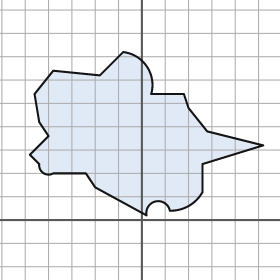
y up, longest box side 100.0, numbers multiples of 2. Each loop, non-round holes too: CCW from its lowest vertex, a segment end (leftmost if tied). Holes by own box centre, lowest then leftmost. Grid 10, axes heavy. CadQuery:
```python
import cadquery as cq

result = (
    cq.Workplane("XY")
    .moveTo(2.0, 2.0)
    .threePointArc((6.0, 8.0), (12.0, 4.0))
    .threePointArc((20.0, 6.0), (26.0, 12.0))
    .lineTo(26.0, 24.0)
    .lineTo(52.0, 32.0)
    .lineTo(28.0, 38.0)
    .lineTo(20.0, 48.0)
    .lineTo(18.0, 54.0)
    .lineTo(4.0, 54.0)
    .threePointArc((2.0, 66.0), (-8.0, 72.0))
    .lineTo(-18.0, 62.0)
    .lineTo(-38.0, 64.0)
    .lineTo(-46.0, 54.0)
    .lineTo(-44.0, 42.0)
    .lineTo(-40.0, 36.0)
    .lineTo(-48.0, 28.0)
    .lineTo(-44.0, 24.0)
    .threePointArc((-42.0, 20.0), (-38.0, 20.0))
    .lineTo(-24.0, 20.0)
    .lineTo(-20.0, 14.0)
    .close()
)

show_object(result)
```